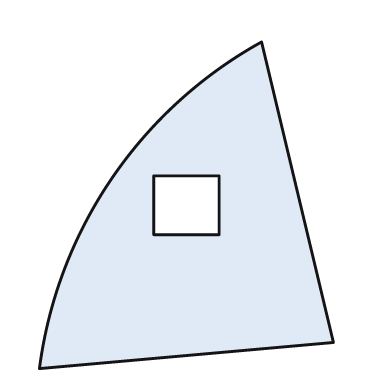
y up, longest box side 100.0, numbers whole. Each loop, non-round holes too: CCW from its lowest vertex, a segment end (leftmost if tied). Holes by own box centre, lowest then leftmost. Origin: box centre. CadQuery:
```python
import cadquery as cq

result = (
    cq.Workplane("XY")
    .moveTo(-45.0, -50.0)
    .lineTo(45.0, -42.0)
    .lineTo(23.0, 50.0)
    .threePointArc((-23.0, 8.0), (-45.0, -50.0))
    .close()
    .moveTo(-10.0, -9.0)
    .lineTo(10.0, -9.0)
    .lineTo(10.0, 9.0)
    .lineTo(-10.0, 9.0)
    .close()
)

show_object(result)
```